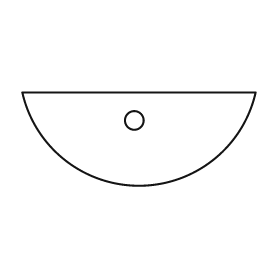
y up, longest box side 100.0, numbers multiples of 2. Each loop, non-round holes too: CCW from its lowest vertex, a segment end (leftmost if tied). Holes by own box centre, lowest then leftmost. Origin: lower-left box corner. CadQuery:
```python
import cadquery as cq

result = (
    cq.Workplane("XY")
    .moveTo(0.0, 40.0)
    .threePointArc((50.0, 0.0), (100.0, 40.0))
    .close()
    .moveTo(48.0, 28.0)
    .circle(4.0)
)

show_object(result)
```